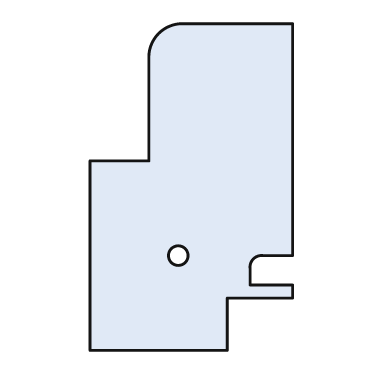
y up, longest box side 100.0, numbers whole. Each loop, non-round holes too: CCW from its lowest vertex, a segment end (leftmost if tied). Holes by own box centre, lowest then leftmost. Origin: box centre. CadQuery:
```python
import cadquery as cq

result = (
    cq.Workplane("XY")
    .moveTo(-31.0, -50.0)
    .lineTo(11.0, -50.0)
    .lineTo(11.0, -34.0)
    .lineTo(31.0, -34.0)
    .lineTo(31.0, -30.0)
    .lineTo(18.0, -30.0)
    .lineTo(18.0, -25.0)
    .threePointArc((19.0, -22.0), (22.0, -21.0))
    .lineTo(31.0, -21.0)
    .lineTo(31.0, 50.0)
    .lineTo(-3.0, 50.0)
    .threePointArc((-10.0, 47.0), (-13.0, 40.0))
    .lineTo(-13.0, 8.0)
    .lineTo(-31.0, 8.0)
    .close()
    .moveTo(-4.0, -21.0)
    .circle(3.0)
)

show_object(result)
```